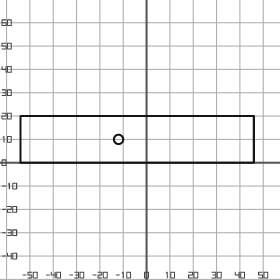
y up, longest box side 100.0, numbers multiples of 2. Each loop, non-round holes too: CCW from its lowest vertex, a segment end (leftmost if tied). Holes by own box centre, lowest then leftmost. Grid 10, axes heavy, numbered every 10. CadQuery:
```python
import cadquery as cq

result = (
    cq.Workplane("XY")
    .moveTo(-54.0, 0.0)
    .lineTo(46.0, 0.0)
    .lineTo(46.0, 20.0)
    .lineTo(-54.0, 20.0)
    .close()
    .moveTo(-12.0, 10.0)
    .circle(2.0)
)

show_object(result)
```